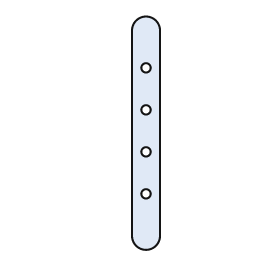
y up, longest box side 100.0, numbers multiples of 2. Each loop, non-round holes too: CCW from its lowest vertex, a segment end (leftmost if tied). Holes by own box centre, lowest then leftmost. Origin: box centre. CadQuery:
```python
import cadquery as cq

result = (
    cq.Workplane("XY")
    .moveTo(-6.0, -44.0)
    .threePointArc((0.0, -50.0), (6.0, -44.0))
    .lineTo(6.0, 44.0)
    .threePointArc((0.0, 50.0), (-6.0, 44.0))
    .close()
    .moveTo(0.0, -26.0)
    .circle(2.0)
    .moveTo(0.0, -8.0)
    .circle(2.0)
    .moveTo(0.0, 10.0)
    .circle(2.0)
    .moveTo(0.0, 28.0)
    .circle(2.0)
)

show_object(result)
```